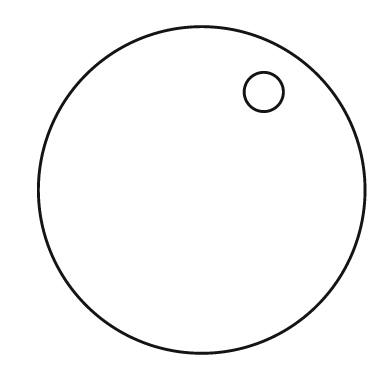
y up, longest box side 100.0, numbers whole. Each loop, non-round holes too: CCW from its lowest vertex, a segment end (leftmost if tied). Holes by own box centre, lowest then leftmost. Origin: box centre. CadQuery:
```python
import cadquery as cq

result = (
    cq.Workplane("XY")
    .moveTo(0.0, 0.0)
    .circle(50.0)
    .moveTo(19.0, 30.0)
    .circle(6.0)
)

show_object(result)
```